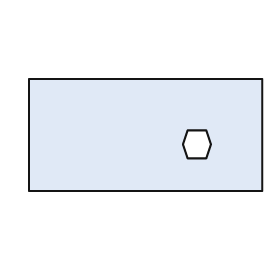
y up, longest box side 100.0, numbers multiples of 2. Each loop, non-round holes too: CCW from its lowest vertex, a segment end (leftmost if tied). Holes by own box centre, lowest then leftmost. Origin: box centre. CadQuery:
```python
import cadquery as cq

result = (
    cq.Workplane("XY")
    .moveTo(-50.0, -24.0)
    .lineTo(50.0, -24.0)
    .lineTo(50.0, 24.0)
    .lineTo(-50.0, 24.0)
    .close()
    .moveTo(18.0, -10.0)
    .lineTo(26.0, -10.0)
    .lineTo(28.0, -4.0)
    .lineTo(26.0, 2.0)
    .lineTo(18.0, 2.0)
    .lineTo(16.0, -4.0)
    .close()
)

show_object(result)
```